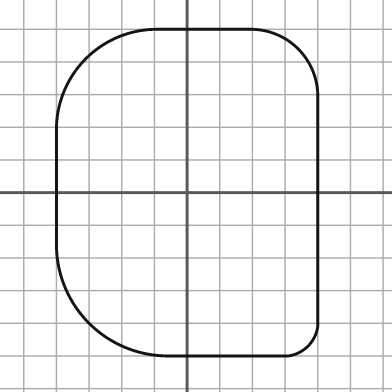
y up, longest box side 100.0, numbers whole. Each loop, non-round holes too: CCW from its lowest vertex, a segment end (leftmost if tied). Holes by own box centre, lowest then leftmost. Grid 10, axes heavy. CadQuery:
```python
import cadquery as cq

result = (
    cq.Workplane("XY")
    .moveTo(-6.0, -50.0)
    .lineTo(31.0, -50.0)
    .threePointArc((37.0, -47.0), (40.0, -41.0))
    .lineTo(40.0, 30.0)
    .threePointArc((34.0, 44.0), (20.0, 50.0))
    .lineTo(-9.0, 50.0)
    .threePointArc((-31.0, 41.0), (-40.0, 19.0))
    .lineTo(-40.0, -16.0)
    .threePointArc((-30.0, -40.0), (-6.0, -50.0))
    .close()
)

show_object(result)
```